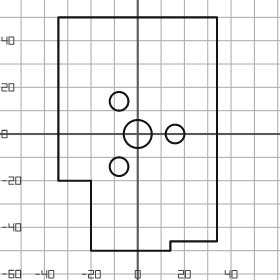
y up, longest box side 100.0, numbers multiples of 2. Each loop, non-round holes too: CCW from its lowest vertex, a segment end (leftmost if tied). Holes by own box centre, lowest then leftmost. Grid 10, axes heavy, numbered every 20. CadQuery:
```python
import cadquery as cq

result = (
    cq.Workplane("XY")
    .moveTo(-20.0, -50.0)
    .lineTo(14.0, -50.0)
    .lineTo(14.0, -46.0)
    .lineTo(34.0, -46.0)
    .lineTo(34.0, 50.0)
    .lineTo(-34.0, 50.0)
    .lineTo(-34.0, -20.0)
    .lineTo(-20.0, -20.0)
    .close()
    .moveTo(-8.0, -14.0)
    .circle(4.0)
    .moveTo(0.0, 0.0)
    .circle(6.0)
    .moveTo(16.0, 0.0)
    .circle(4.0)
    .moveTo(-8.0, 14.0)
    .circle(4.0)
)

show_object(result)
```